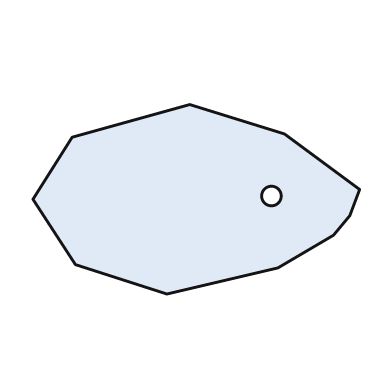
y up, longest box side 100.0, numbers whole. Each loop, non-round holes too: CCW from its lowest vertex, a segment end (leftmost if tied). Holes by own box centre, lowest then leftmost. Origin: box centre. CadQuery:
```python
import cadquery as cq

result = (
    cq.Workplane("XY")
    .moveTo(-9.0, -29.0)
    .lineTo(25.0, -21.0)
    .lineTo(42.0, -11.0)
    .lineTo(47.0, -5.0)
    .lineTo(50.0, 3.0)
    .lineTo(27.0, 20.0)
    .lineTo(-2.0, 29.0)
    .lineTo(-38.0, 19.0)
    .lineTo(-50.0, 0.0)
    .lineTo(-37.0, -20.0)
    .close()
    .moveTo(23.0, 1.0)
    .circle(3.0)
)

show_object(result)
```